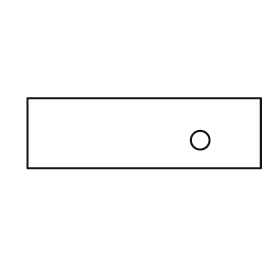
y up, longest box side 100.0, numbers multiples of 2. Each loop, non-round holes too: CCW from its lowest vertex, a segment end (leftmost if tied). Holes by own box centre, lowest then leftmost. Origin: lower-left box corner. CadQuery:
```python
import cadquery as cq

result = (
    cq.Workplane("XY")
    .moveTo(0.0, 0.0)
    .lineTo(100.0, 0.0)
    .lineTo(100.0, 30.0)
    .lineTo(0.0, 30.0)
    .close()
    .moveTo(74.0, 12.0)
    .circle(4.0)
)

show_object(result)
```